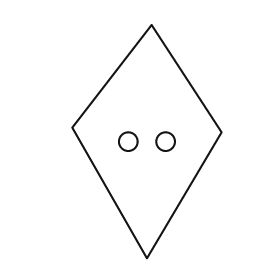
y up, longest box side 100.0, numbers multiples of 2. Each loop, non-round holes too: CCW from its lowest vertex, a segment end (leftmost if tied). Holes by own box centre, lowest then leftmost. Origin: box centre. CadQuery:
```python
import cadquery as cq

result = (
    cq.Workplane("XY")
    .moveTo(0.0, -50.0)
    .lineTo(32.0, 4.0)
    .lineTo(2.0, 50.0)
    .lineTo(-32.0, 6.0)
    .close()
    .moveTo(-8.0, 0.0)
    .circle(4.0)
    .moveTo(8.0, 0.0)
    .circle(4.0)
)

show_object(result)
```